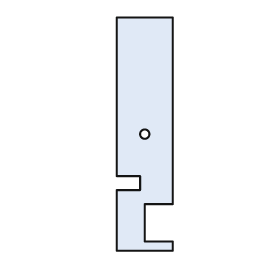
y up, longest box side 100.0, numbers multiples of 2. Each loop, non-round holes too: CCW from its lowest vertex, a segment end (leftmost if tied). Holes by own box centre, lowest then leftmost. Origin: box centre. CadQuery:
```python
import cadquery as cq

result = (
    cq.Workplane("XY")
    .moveTo(-12.0, -50.0)
    .lineTo(12.0, -50.0)
    .lineTo(12.0, -46.0)
    .lineTo(0.0, -46.0)
    .lineTo(0.0, -30.0)
    .lineTo(12.0, -30.0)
    .lineTo(12.0, 50.0)
    .lineTo(-12.0, 50.0)
    .lineTo(-12.0, -18.0)
    .lineTo(-2.0, -18.0)
    .lineTo(-2.0, -24.0)
    .lineTo(-12.0, -24.0)
    .close()
    .moveTo(0.0, 0.0)
    .circle(2.0)
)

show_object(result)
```